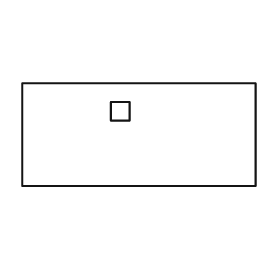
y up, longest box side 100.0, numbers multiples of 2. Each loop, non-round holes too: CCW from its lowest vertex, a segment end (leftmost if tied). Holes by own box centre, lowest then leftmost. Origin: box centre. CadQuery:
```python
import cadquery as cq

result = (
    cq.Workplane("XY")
    .moveTo(-50.0, -22.0)
    .lineTo(50.0, -22.0)
    .lineTo(50.0, 22.0)
    .lineTo(-50.0, 22.0)
    .close()
    .moveTo(-12.0, 6.0)
    .lineTo(-4.0, 6.0)
    .lineTo(-4.0, 14.0)
    .lineTo(-12.0, 14.0)
    .close()
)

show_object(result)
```